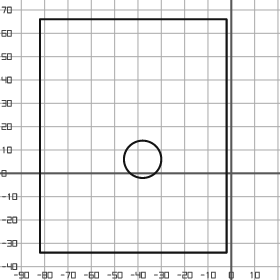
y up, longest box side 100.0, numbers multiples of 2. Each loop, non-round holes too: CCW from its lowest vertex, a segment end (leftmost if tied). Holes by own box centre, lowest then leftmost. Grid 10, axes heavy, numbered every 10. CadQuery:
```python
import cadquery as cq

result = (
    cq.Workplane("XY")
    .moveTo(-82.0, -34.0)
    .lineTo(-2.0, -34.0)
    .lineTo(-2.0, 66.0)
    .lineTo(-82.0, 66.0)
    .close()
    .moveTo(-38.0, 6.0)
    .circle(8.0)
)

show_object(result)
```